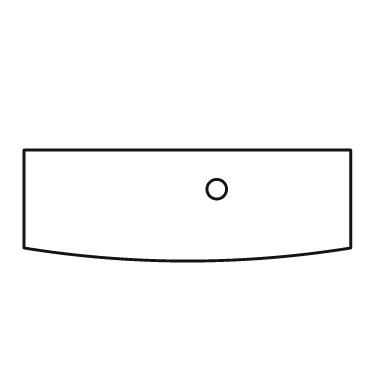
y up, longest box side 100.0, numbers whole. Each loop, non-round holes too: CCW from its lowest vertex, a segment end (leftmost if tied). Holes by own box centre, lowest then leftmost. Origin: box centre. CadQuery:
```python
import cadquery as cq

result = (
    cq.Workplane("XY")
    .moveTo(-50.0, -13.0)
    .threePointArc((0.0, -17.0), (50.0, -13.0))
    .lineTo(50.0, 17.0)
    .lineTo(-50.0, 17.0)
    .close()
    .moveTo(9.0, 5.0)
    .circle(3.0)
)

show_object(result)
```